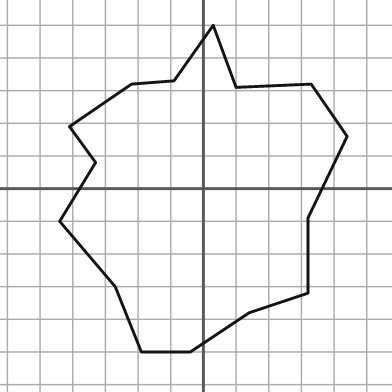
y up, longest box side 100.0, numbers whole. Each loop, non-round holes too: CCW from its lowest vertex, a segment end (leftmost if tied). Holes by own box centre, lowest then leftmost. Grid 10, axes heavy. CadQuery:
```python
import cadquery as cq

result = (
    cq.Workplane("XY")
    .moveTo(-19.0, -50.0)
    .lineTo(-4.0, -50.0)
    .lineTo(14.0, -38.0)
    .lineTo(32.0, -32.0)
    .lineTo(32.0, -9.0)
    .lineTo(44.0, 16.0)
    .lineTo(33.0, 32.0)
    .lineTo(10.0, 31.0)
    .lineTo(3.0, 50.0)
    .lineTo(-9.0, 33.0)
    .lineTo(-22.0, 32.0)
    .lineTo(-41.0, 19.0)
    .lineTo(-33.0, 8.0)
    .lineTo(-44.0, -10.0)
    .lineTo(-27.0, -30.0)
    .close()
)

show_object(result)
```